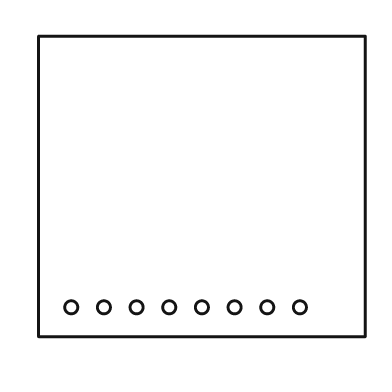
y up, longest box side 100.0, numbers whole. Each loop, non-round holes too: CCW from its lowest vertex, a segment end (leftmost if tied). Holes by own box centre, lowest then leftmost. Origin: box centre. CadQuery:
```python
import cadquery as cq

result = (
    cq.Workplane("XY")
    .moveTo(-50.0, -46.0)
    .lineTo(50.0, -46.0)
    .lineTo(50.0, 46.0)
    .lineTo(-50.0, 46.0)
    .close()
    .moveTo(-40.0, -37.0)
    .circle(2.0)
    .moveTo(-30.0, -37.0)
    .circle(2.0)
    .moveTo(-20.0, -37.0)
    .circle(2.0)
    .moveTo(-10.0, -37.0)
    .circle(2.0)
    .moveTo(0.0, -37.0)
    .circle(2.0)
    .moveTo(10.0, -37.0)
    .circle(2.0)
    .moveTo(20.0, -37.0)
    .circle(2.0)
    .moveTo(30.0, -37.0)
    .circle(2.0)
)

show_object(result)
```